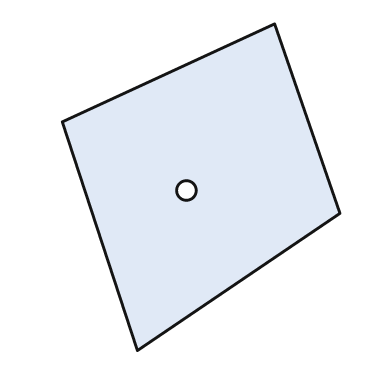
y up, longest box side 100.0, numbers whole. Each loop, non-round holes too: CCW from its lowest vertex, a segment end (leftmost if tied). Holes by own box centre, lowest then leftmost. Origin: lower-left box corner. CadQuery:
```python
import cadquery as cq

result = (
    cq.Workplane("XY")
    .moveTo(23.0, 0.0)
    .lineTo(85.0, 42.0)
    .lineTo(65.0, 100.0)
    .lineTo(0.0, 70.0)
    .close()
    .moveTo(38.0, 49.0)
    .circle(3.0)
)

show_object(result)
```